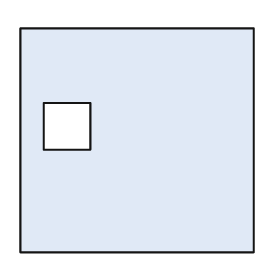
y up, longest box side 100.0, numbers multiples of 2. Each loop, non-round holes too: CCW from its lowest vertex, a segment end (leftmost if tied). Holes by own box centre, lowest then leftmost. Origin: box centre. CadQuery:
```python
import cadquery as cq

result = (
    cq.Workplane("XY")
    .moveTo(-50.0, -48.0)
    .lineTo(50.0, -48.0)
    .lineTo(50.0, 48.0)
    .lineTo(-50.0, 48.0)
    .close()
    .moveTo(-40.0, -4.0)
    .lineTo(-20.0, -4.0)
    .lineTo(-20.0, 16.0)
    .lineTo(-40.0, 16.0)
    .close()
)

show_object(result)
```